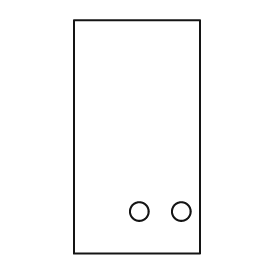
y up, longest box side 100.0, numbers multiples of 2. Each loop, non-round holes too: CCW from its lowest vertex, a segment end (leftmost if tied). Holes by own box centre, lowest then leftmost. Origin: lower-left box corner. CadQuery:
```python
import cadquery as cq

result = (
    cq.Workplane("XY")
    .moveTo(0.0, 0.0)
    .lineTo(54.0, 0.0)
    .lineTo(54.0, 100.0)
    .lineTo(0.0, 100.0)
    .close()
    .moveTo(28.0, 18.0)
    .circle(4.0)
    .moveTo(46.0, 18.0)
    .circle(4.0)
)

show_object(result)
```